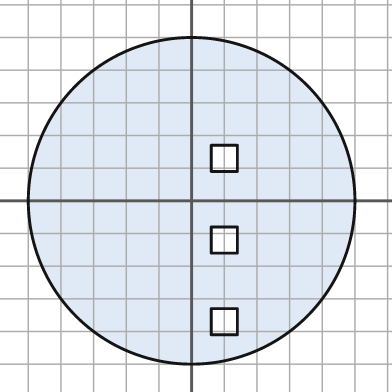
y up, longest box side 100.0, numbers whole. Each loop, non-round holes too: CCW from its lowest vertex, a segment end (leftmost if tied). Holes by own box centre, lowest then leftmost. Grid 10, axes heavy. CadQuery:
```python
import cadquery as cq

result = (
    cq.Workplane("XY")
    .moveTo(0.0, 0.0)
    .circle(50.0)
    .moveTo(6.0, -41.0)
    .lineTo(14.0, -41.0)
    .lineTo(14.0, -33.0)
    .lineTo(6.0, -33.0)
    .close()
    .moveTo(6.0, -16.0)
    .lineTo(14.0, -16.0)
    .lineTo(14.0, -8.0)
    .lineTo(6.0, -8.0)
    .close()
    .moveTo(6.0, 9.0)
    .lineTo(14.0, 9.0)
    .lineTo(14.0, 17.0)
    .lineTo(6.0, 17.0)
    .close()
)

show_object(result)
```